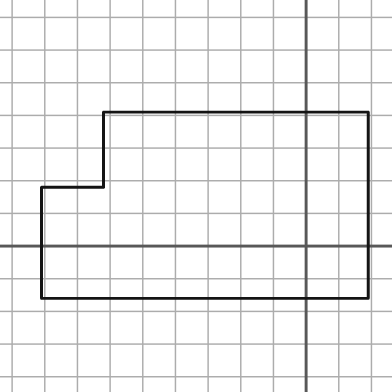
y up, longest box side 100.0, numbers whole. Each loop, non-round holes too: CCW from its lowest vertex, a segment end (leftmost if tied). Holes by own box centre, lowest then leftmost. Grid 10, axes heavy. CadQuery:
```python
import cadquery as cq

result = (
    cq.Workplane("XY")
    .moveTo(-81.0, -16.0)
    .lineTo(19.0, -16.0)
    .lineTo(19.0, 41.0)
    .lineTo(-62.0, 41.0)
    .lineTo(-62.0, 18.0)
    .lineTo(-81.0, 18.0)
    .close()
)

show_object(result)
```